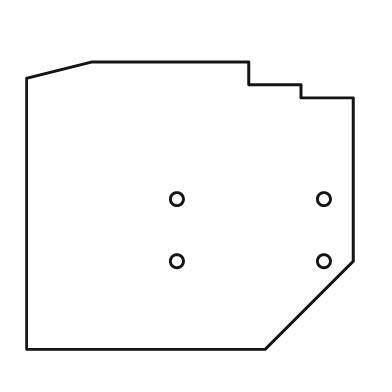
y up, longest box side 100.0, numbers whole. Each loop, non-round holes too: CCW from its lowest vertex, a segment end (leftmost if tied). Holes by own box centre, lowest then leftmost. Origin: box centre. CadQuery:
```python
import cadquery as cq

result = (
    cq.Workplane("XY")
    .moveTo(-50.0, -44.0)
    .lineTo(23.0, -44.0)
    .lineTo(50.0, -17.0)
    .lineTo(50.0, 33.0)
    .lineTo(34.0, 33.0)
    .lineTo(34.0, 37.0)
    .lineTo(18.0, 37.0)
    .lineTo(18.0, 44.0)
    .lineTo(-30.0, 44.0)
    .lineTo(-50.0, 39.0)
    .close()
    .moveTo(-4.0, -17.0)
    .circle(2.0)
    .moveTo(41.0, -17.0)
    .circle(2.0)
    .moveTo(-4.0, 2.0)
    .circle(2.0)
    .moveTo(41.0, 2.0)
    .circle(2.0)
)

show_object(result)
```